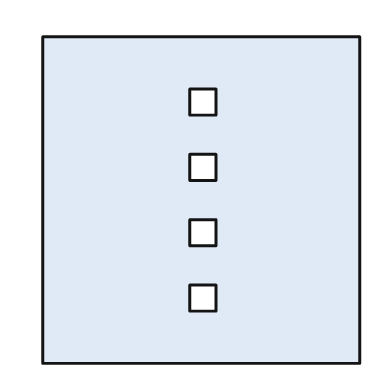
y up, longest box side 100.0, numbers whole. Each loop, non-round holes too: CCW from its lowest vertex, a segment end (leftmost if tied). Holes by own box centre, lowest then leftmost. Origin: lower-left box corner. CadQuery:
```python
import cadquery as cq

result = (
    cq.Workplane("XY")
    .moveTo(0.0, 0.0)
    .lineTo(97.0, 0.0)
    .lineTo(97.0, 100.0)
    .lineTo(0.0, 100.0)
    .close()
    .moveTo(45.0, 16.0)
    .lineTo(53.0, 16.0)
    .lineTo(53.0, 24.0)
    .lineTo(45.0, 24.0)
    .close()
    .moveTo(45.0, 36.0)
    .lineTo(53.0, 36.0)
    .lineTo(53.0, 44.0)
    .lineTo(45.0, 44.0)
    .close()
    .moveTo(45.0, 56.0)
    .lineTo(53.0, 56.0)
    .lineTo(53.0, 64.0)
    .lineTo(45.0, 64.0)
    .close()
    .moveTo(45.0, 76.0)
    .lineTo(53.0, 76.0)
    .lineTo(53.0, 84.0)
    .lineTo(45.0, 84.0)
    .close()
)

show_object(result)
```